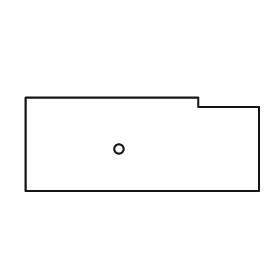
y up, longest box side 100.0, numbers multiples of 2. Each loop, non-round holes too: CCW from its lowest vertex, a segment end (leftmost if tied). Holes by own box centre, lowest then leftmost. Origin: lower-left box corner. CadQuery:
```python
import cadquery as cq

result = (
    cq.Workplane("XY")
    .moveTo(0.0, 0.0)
    .lineTo(100.0, 0.0)
    .lineTo(100.0, 36.0)
    .lineTo(74.0, 36.0)
    .lineTo(74.0, 40.0)
    .lineTo(0.0, 40.0)
    .close()
    .moveTo(40.0, 18.0)
    .circle(2.0)
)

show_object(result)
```